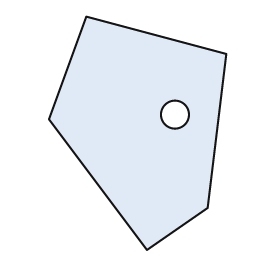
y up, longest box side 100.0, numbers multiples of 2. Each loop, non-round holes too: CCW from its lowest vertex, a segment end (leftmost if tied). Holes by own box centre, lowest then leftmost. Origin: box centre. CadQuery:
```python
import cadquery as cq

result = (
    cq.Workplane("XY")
    .moveTo(4.0, -50.0)
    .lineTo(30.0, -32.0)
    .lineTo(38.0, 34.0)
    .lineTo(-22.0, 50.0)
    .lineTo(-38.0, 6.0)
    .close()
    .moveTo(16.0, 8.0)
    .circle(6.0)
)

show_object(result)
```